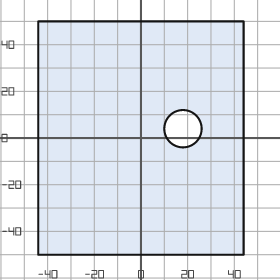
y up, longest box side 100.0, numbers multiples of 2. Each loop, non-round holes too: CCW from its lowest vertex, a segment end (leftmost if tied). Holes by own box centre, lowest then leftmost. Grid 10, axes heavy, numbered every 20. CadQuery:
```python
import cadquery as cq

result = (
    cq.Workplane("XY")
    .moveTo(-44.0, -50.0)
    .lineTo(44.0, -50.0)
    .lineTo(44.0, 50.0)
    .lineTo(-44.0, 50.0)
    .close()
    .moveTo(18.0, 4.0)
    .circle(8.0)
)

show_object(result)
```